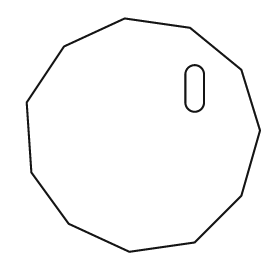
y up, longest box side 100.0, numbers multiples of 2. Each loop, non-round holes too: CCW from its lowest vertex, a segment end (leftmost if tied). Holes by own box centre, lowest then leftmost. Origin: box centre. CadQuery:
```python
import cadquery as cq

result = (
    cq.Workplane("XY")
    .moveTo(-6.0, -50.0)
    .lineTo(22.0, -46.0)
    .lineTo(42.0, -26.0)
    .lineTo(50.0, 2.0)
    .lineTo(42.0, 28.0)
    .lineTo(20.0, 46.0)
    .lineTo(-8.0, 50.0)
    .lineTo(-34.0, 38.0)
    .lineTo(-50.0, 14.0)
    .lineTo(-48.0, -16.0)
    .lineTo(-32.0, -38.0)
    .close()
    .moveTo(18.0, 14.0)
    .threePointArc((22.0, 10.0), (26.0, 14.0))
    .lineTo(26.0, 26.0)
    .threePointArc((22.0, 30.0), (18.0, 26.0))
    .close()
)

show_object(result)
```